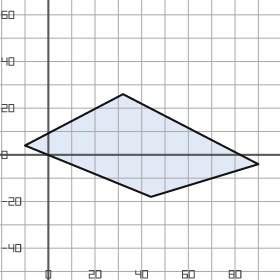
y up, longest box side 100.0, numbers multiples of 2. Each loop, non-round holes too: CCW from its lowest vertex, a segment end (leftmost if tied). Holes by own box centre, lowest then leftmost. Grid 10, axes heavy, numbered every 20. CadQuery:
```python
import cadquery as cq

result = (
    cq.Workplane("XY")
    .moveTo(44.0, -18.0)
    .lineTo(90.0, -4.0)
    .lineTo(32.0, 26.0)
    .lineTo(-10.0, 4.0)
    .close()
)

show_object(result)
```